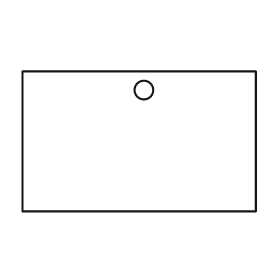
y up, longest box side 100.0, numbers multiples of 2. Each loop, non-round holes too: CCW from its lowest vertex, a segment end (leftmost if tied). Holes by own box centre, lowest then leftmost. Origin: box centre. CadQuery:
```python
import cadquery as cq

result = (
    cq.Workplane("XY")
    .moveTo(-50.0, -30.0)
    .lineTo(50.0, -30.0)
    .lineTo(50.0, 30.0)
    .lineTo(-50.0, 30.0)
    .close()
    .moveTo(2.0, 22.0)
    .circle(4.0)
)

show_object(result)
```